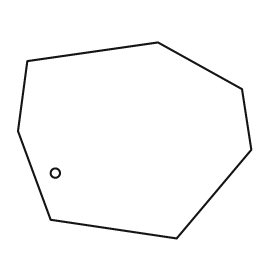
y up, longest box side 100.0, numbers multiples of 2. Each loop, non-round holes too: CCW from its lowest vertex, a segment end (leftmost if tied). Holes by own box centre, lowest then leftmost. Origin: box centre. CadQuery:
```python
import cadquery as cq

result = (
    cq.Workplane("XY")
    .moveTo(18.0, -42.0)
    .lineTo(50.0, -4.0)
    .lineTo(46.0, 22.0)
    .lineTo(10.0, 42.0)
    .lineTo(-46.0, 34.0)
    .lineTo(-50.0, 4.0)
    .lineTo(-36.0, -34.0)
    .close()
    .moveTo(-34.0, -14.0)
    .circle(2.0)
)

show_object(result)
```